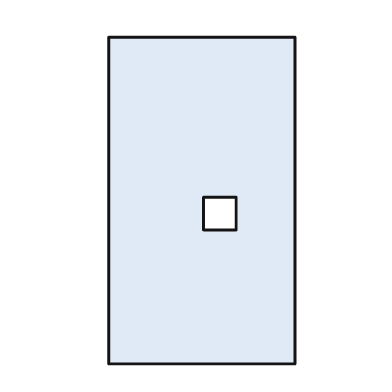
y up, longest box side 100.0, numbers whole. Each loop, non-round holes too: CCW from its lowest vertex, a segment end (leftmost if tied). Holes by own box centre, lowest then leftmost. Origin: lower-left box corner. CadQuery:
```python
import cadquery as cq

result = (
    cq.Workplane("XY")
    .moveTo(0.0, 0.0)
    .lineTo(57.0, 0.0)
    .lineTo(57.0, 100.0)
    .lineTo(0.0, 100.0)
    .close()
    .moveTo(29.0, 41.0)
    .lineTo(39.0, 41.0)
    .lineTo(39.0, 51.0)
    .lineTo(29.0, 51.0)
    .close()
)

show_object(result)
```